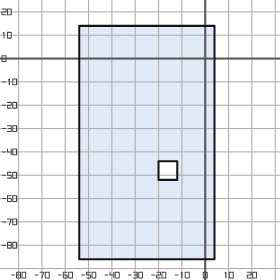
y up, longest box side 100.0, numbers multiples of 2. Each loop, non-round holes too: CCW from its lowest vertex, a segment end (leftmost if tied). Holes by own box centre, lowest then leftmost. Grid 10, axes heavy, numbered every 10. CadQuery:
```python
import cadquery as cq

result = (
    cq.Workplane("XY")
    .moveTo(-54.0, -86.0)
    .lineTo(4.0, -86.0)
    .lineTo(4.0, 14.0)
    .lineTo(-54.0, 14.0)
    .close()
    .moveTo(-20.0, -52.0)
    .lineTo(-12.0, -52.0)
    .lineTo(-12.0, -44.0)
    .lineTo(-20.0, -44.0)
    .close()
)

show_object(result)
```